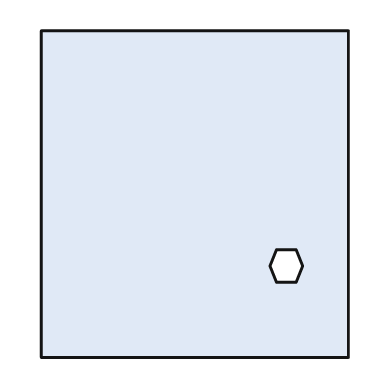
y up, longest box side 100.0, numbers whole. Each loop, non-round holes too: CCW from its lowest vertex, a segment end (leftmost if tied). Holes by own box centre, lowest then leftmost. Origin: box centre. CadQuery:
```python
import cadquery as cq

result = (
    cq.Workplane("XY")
    .moveTo(-47.0, -50.0)
    .lineTo(47.0, -50.0)
    .lineTo(47.0, 50.0)
    .lineTo(-47.0, 50.0)
    .close()
    .moveTo(25.0, -27.0)
    .lineTo(31.0, -27.0)
    .lineTo(33.0, -22.0)
    .lineTo(31.0, -17.0)
    .lineTo(25.0, -17.0)
    .lineTo(23.0, -22.0)
    .close()
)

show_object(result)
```